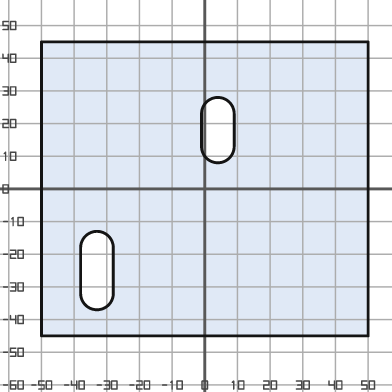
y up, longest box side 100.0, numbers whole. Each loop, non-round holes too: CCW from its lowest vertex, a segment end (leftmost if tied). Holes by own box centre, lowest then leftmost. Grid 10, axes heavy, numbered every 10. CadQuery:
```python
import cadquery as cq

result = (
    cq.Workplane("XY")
    .moveTo(-50.0, -45.0)
    .lineTo(50.0, -45.0)
    .lineTo(50.0, 45.0)
    .lineTo(-50.0, 45.0)
    .close()
    .moveTo(-38.0, -32.0)
    .threePointArc((-33.0, -37.0), (-28.0, -32.0))
    .lineTo(-28.0, -18.0)
    .threePointArc((-33.0, -13.0), (-38.0, -18.0))
    .close()
    .moveTo(-1.0, 13.0)
    .threePointArc((4.0, 8.0), (9.0, 13.0))
    .lineTo(9.0, 23.0)
    .threePointArc((4.0, 28.0), (-1.0, 23.0))
    .close()
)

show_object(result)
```